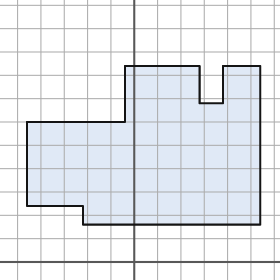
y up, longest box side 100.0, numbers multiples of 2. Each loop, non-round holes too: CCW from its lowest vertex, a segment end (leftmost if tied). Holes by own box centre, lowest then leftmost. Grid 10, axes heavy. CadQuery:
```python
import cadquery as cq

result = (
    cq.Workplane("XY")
    .moveTo(-22.0, 16.0)
    .lineTo(54.0, 16.0)
    .lineTo(54.0, 84.0)
    .lineTo(38.0, 84.0)
    .lineTo(38.0, 68.0)
    .lineTo(28.0, 68.0)
    .lineTo(28.0, 84.0)
    .lineTo(-4.0, 84.0)
    .lineTo(-4.0, 60.0)
    .lineTo(-46.0, 60.0)
    .lineTo(-46.0, 24.0)
    .lineTo(-22.0, 24.0)
    .close()
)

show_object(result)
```